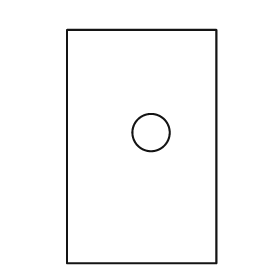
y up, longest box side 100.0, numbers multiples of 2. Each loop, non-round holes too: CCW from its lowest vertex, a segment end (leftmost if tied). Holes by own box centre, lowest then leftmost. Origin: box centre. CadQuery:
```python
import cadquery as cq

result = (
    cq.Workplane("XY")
    .moveTo(-32.0, -50.0)
    .lineTo(32.0, -50.0)
    .lineTo(32.0, 50.0)
    .lineTo(-32.0, 50.0)
    .close()
    .moveTo(4.0, 6.0)
    .circle(8.0)
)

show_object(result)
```